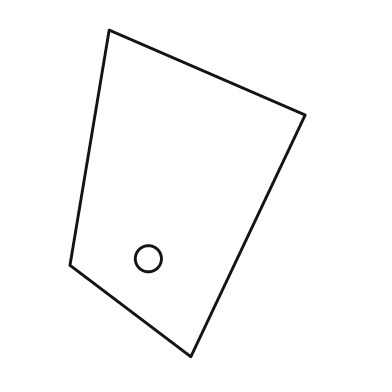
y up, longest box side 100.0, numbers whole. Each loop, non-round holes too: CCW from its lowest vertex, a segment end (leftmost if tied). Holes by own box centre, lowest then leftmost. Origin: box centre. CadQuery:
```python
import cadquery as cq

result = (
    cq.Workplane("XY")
    .moveTo(1.0, -50.0)
    .lineTo(36.0, 24.0)
    .lineTo(-24.0, 50.0)
    .lineTo(-36.0, -22.0)
    .close()
    .moveTo(-12.0, -20.0)
    .circle(4.0)
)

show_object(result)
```